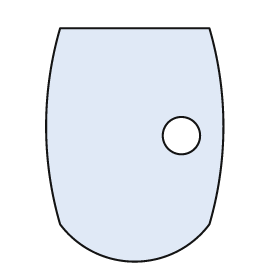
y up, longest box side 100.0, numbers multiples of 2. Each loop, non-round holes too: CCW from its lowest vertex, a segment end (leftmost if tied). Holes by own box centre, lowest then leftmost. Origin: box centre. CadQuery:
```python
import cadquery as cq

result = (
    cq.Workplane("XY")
    .moveTo(-32.0, -34.0)
    .threePointArc((0.0, -50.0), (32.0, -34.0))
    .threePointArc((38.0, 8.0), (32.0, 50.0))
    .lineTo(-32.0, 50.0)
    .threePointArc((-38.0, 8.0), (-32.0, -34.0))
    .close()
    .moveTo(20.0, 4.0)
    .circle(8.0)
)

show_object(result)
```